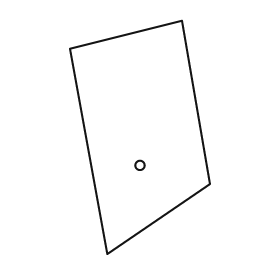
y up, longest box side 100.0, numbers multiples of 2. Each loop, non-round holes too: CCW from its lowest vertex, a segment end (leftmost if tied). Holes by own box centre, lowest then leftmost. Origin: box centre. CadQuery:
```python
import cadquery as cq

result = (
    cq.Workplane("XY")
    .moveTo(-14.0, -50.0)
    .lineTo(30.0, -20.0)
    .lineTo(18.0, 50.0)
    .lineTo(-30.0, 38.0)
    .close()
    .moveTo(0.0, -12.0)
    .circle(2.0)
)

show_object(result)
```